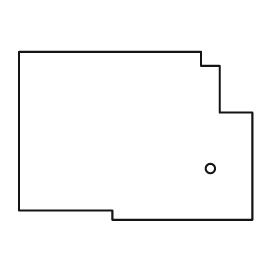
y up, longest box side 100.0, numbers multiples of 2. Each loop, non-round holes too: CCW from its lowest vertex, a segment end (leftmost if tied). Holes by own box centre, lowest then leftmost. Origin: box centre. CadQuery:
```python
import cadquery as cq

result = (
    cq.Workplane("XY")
    .moveTo(-10.0, -36.0)
    .lineTo(50.0, -36.0)
    .lineTo(50.0, 10.0)
    .lineTo(36.0, 10.0)
    .lineTo(36.0, 30.0)
    .lineTo(28.0, 30.0)
    .lineTo(28.0, 36.0)
    .lineTo(-50.0, 36.0)
    .lineTo(-50.0, -32.0)
    .lineTo(-10.0, -32.0)
    .close()
    .moveTo(32.0, -14.0)
    .circle(2.0)
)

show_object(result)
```